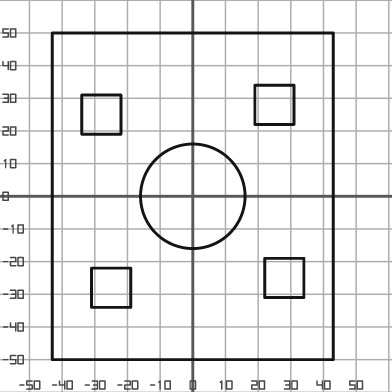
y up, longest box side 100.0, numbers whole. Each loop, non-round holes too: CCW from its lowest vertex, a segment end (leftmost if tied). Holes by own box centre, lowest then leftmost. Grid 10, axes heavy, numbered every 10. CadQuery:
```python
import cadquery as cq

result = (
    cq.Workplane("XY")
    .moveTo(-43.0, -50.0)
    .lineTo(43.0, -50.0)
    .lineTo(43.0, 50.0)
    .lineTo(-43.0, 50.0)
    .close()
    .moveTo(-31.0, -34.0)
    .lineTo(-19.0, -34.0)
    .lineTo(-19.0, -22.0)
    .lineTo(-31.0, -22.0)
    .close()
    .moveTo(22.0, -31.0)
    .lineTo(34.0, -31.0)
    .lineTo(34.0, -19.0)
    .lineTo(22.0, -19.0)
    .close()
    .moveTo(0.0, 0.0)
    .circle(16.0)
    .moveTo(-34.0, 19.0)
    .lineTo(-22.0, 19.0)
    .lineTo(-22.0, 31.0)
    .lineTo(-34.0, 31.0)
    .close()
    .moveTo(19.0, 22.0)
    .lineTo(31.0, 22.0)
    .lineTo(31.0, 34.0)
    .lineTo(19.0, 34.0)
    .close()
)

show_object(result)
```